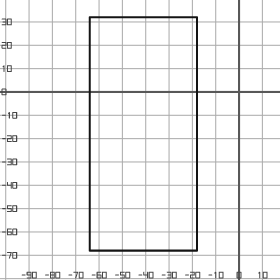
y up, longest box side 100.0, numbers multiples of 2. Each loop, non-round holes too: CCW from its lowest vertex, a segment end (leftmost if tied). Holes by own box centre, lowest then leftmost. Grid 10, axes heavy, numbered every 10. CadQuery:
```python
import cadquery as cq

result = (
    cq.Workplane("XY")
    .moveTo(-64.0, -68.0)
    .lineTo(-18.0, -68.0)
    .lineTo(-18.0, 32.0)
    .lineTo(-64.0, 32.0)
    .close()
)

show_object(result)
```